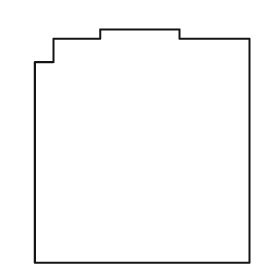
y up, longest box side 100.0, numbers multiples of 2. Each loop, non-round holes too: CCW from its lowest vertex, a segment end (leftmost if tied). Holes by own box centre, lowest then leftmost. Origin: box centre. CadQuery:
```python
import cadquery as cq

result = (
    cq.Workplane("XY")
    .moveTo(-46.0, -50.0)
    .lineTo(46.0, -50.0)
    .lineTo(46.0, 46.0)
    .lineTo(16.0, 46.0)
    .lineTo(16.0, 50.0)
    .lineTo(-18.0, 50.0)
    .lineTo(-18.0, 46.0)
    .lineTo(-38.0, 46.0)
    .lineTo(-38.0, 36.0)
    .lineTo(-46.0, 36.0)
    .close()
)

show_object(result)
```